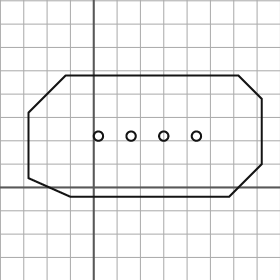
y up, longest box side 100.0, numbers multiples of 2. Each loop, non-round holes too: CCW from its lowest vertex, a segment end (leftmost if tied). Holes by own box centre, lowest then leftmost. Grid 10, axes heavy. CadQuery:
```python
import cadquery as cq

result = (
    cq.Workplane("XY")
    .moveTo(-10.0, -4.0)
    .lineTo(58.0, -4.0)
    .lineTo(72.0, 10.0)
    .lineTo(72.0, 38.0)
    .lineTo(62.0, 48.0)
    .lineTo(-12.0, 48.0)
    .lineTo(-28.0, 32.0)
    .lineTo(-28.0, 4.0)
    .close()
    .moveTo(2.0, 22.0)
    .circle(2.0)
    .moveTo(16.0, 22.0)
    .circle(2.0)
    .moveTo(30.0, 22.0)
    .circle(2.0)
    .moveTo(44.0, 22.0)
    .circle(2.0)
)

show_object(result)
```